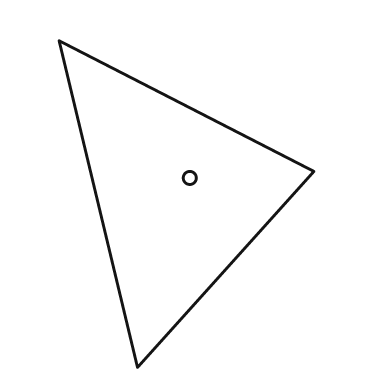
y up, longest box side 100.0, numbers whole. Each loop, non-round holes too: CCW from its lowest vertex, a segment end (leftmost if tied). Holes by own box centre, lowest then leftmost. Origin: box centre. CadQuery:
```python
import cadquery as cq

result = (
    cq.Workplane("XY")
    .moveTo(-15.0, -50.0)
    .lineTo(39.0, 10.0)
    .lineTo(-39.0, 50.0)
    .close()
    .moveTo(1.0, 8.0)
    .circle(2.0)
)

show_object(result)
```